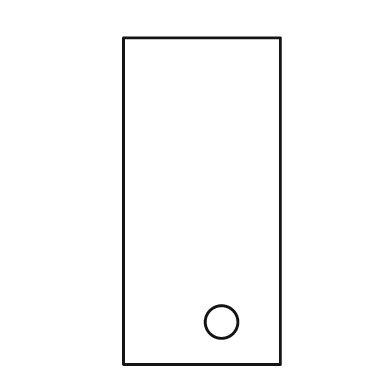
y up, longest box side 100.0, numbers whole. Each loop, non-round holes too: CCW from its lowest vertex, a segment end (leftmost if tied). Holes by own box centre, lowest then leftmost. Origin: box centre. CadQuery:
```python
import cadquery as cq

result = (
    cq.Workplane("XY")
    .moveTo(-24.0, -50.0)
    .lineTo(24.0, -50.0)
    .lineTo(24.0, 50.0)
    .lineTo(-24.0, 50.0)
    .close()
    .moveTo(6.0, -37.0)
    .circle(5.0)
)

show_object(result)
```